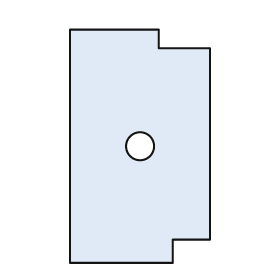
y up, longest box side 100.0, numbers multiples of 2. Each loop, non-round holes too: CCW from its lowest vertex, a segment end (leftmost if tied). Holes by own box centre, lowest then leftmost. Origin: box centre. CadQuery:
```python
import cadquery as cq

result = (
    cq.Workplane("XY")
    .moveTo(-30.0, -50.0)
    .lineTo(14.0, -50.0)
    .lineTo(14.0, -40.0)
    .lineTo(30.0, -40.0)
    .lineTo(30.0, 42.0)
    .lineTo(8.0, 42.0)
    .lineTo(8.0, 50.0)
    .lineTo(-30.0, 50.0)
    .close()
    .moveTo(0.0, 0.0)
    .circle(6.0)
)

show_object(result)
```